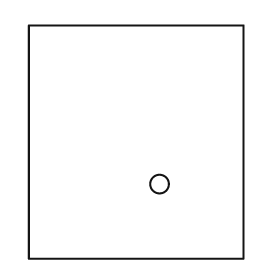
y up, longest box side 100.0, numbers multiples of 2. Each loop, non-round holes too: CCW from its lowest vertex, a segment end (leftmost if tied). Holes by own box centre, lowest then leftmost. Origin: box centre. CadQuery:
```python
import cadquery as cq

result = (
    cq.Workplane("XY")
    .moveTo(-46.0, -50.0)
    .lineTo(46.0, -50.0)
    .lineTo(46.0, 50.0)
    .lineTo(-46.0, 50.0)
    .close()
    .moveTo(10.0, -18.0)
    .circle(4.0)
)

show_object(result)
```